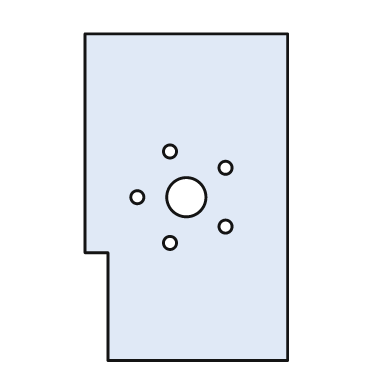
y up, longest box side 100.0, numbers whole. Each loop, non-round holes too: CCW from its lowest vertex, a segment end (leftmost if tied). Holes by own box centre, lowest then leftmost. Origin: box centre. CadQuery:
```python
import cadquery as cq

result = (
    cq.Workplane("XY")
    .moveTo(-24.0, -50.0)
    .lineTo(31.0, -50.0)
    .lineTo(31.0, 50.0)
    .lineTo(-31.0, 50.0)
    .lineTo(-31.0, -17.0)
    .lineTo(-24.0, -17.0)
    .close()
    .moveTo(-5.0, -14.0)
    .circle(2.0)
    .moveTo(12.0, -9.0)
    .circle(2.0)
    .moveTo(-15.0, 0.0)
    .circle(2.0)
    .moveTo(0.0, 0.0)
    .circle(6.0)
    .moveTo(12.0, 9.0)
    .circle(2.0)
    .moveTo(-5.0, 14.0)
    .circle(2.0)
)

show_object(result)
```